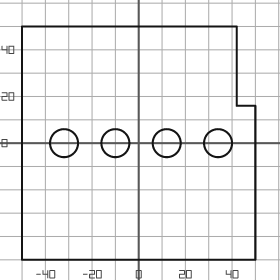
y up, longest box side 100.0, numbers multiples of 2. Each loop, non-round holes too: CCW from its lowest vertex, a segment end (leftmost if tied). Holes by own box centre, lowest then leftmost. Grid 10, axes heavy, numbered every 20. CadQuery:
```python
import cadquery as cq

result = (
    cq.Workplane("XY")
    .moveTo(-50.0, -50.0)
    .lineTo(50.0, -50.0)
    .lineTo(50.0, 16.0)
    .lineTo(42.0, 16.0)
    .lineTo(42.0, 50.0)
    .lineTo(-50.0, 50.0)
    .close()
    .moveTo(-32.0, 0.0)
    .circle(6.0)
    .moveTo(-10.0, 0.0)
    .circle(6.0)
    .moveTo(12.0, 0.0)
    .circle(6.0)
    .moveTo(34.0, 0.0)
    .circle(6.0)
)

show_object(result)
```